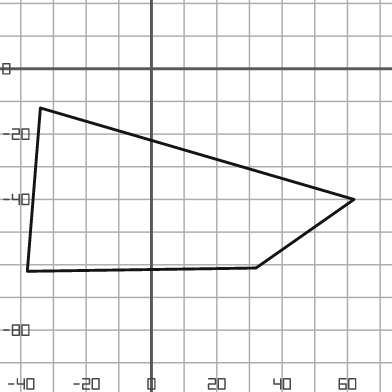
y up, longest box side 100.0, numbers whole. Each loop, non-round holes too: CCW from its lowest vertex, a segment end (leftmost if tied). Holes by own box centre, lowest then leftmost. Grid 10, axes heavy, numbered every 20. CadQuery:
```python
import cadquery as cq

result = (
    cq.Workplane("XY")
    .moveTo(-38.0, -62.0)
    .lineTo(32.0, -61.0)
    .lineTo(62.0, -40.0)
    .lineTo(-34.0, -12.0)
    .close()
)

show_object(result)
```